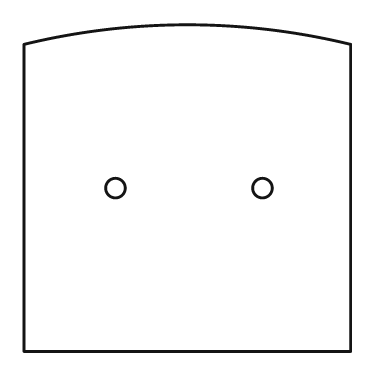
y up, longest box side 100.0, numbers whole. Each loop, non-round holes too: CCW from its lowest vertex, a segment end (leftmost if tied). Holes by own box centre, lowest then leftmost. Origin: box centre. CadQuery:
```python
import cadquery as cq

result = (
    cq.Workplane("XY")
    .moveTo(-50.0, -50.0)
    .lineTo(50.0, -50.0)
    .lineTo(50.0, 44.0)
    .threePointArc((0.0, 50.0), (-50.0, 44.0))
    .close()
    .moveTo(-22.0, 0.0)
    .circle(3.0)
    .moveTo(23.0, 0.0)
    .circle(3.0)
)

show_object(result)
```